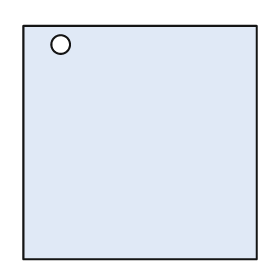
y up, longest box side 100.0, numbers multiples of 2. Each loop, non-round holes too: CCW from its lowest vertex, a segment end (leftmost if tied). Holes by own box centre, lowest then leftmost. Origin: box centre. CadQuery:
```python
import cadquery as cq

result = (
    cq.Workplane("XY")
    .moveTo(-50.0, -50.0)
    .lineTo(50.0, -50.0)
    .lineTo(50.0, 50.0)
    .lineTo(-50.0, 50.0)
    .close()
    .moveTo(-34.0, 42.0)
    .circle(4.0)
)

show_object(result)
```